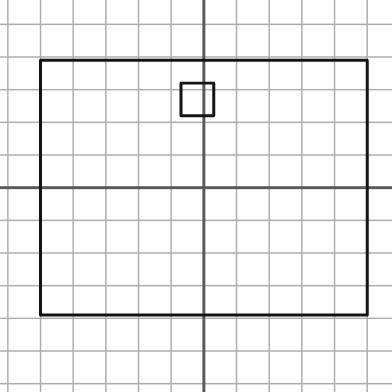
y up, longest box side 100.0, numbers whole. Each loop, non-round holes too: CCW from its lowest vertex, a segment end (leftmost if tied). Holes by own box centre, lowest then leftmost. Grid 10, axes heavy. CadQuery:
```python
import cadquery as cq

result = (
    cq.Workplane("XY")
    .moveTo(-50.0, -39.0)
    .lineTo(50.0, -39.0)
    .lineTo(50.0, 39.0)
    .lineTo(-50.0, 39.0)
    .close()
    .moveTo(-7.0, 22.0)
    .lineTo(3.0, 22.0)
    .lineTo(3.0, 32.0)
    .lineTo(-7.0, 32.0)
    .close()
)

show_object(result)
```